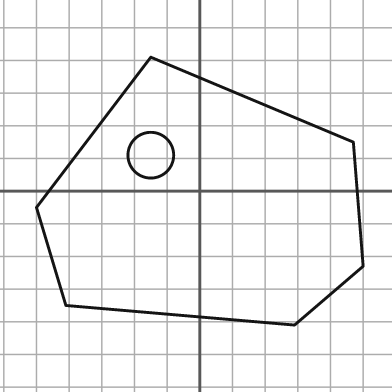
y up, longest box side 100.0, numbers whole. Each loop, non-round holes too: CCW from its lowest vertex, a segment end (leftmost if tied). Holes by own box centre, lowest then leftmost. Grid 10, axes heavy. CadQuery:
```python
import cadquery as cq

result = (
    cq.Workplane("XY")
    .moveTo(29.0, -41.0)
    .lineTo(50.0, -23.0)
    .lineTo(47.0, 15.0)
    .lineTo(-15.0, 41.0)
    .lineTo(-50.0, -5.0)
    .lineTo(-41.0, -35.0)
    .close()
    .moveTo(-15.0, 11.0)
    .circle(7.0)
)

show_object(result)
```